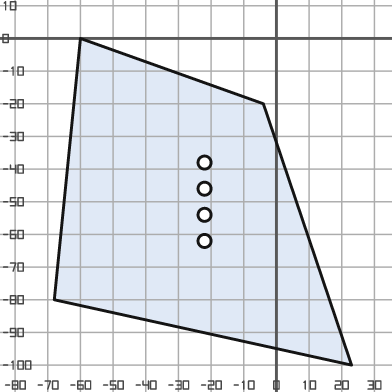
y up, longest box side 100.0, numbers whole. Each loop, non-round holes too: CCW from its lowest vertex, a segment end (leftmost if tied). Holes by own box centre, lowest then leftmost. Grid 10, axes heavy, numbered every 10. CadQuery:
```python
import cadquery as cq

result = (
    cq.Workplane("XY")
    .moveTo(23.0, -100.0)
    .lineTo(-4.0, -20.0)
    .lineTo(-60.0, 0.0)
    .lineTo(-68.0, -80.0)
    .close()
    .moveTo(-22.0, -62.0)
    .circle(2.0)
    .moveTo(-22.0, -54.0)
    .circle(2.0)
    .moveTo(-22.0, -46.0)
    .circle(2.0)
    .moveTo(-22.0, -38.0)
    .circle(2.0)
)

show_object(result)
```